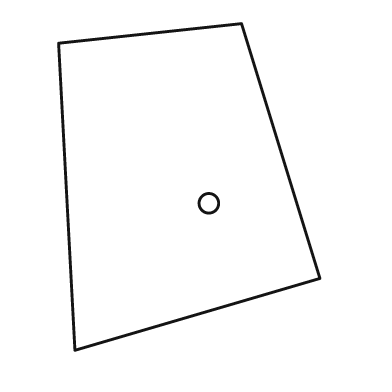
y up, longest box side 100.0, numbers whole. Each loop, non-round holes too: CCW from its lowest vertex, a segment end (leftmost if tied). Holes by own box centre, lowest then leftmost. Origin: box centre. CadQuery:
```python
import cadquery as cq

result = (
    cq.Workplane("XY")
    .moveTo(-35.0, -50.0)
    .lineTo(40.0, -28.0)
    .lineTo(16.0, 50.0)
    .lineTo(-40.0, 44.0)
    .close()
    .moveTo(6.0, -5.0)
    .circle(3.0)
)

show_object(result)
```